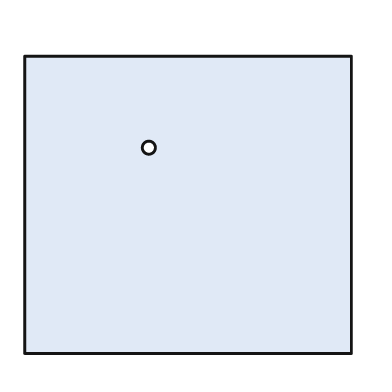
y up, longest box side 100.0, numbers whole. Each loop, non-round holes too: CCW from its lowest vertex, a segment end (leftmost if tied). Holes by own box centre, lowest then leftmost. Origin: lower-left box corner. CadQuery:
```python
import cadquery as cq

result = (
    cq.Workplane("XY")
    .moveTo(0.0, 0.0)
    .lineTo(100.0, 0.0)
    .lineTo(100.0, 91.0)
    .lineTo(0.0, 91.0)
    .close()
    .moveTo(38.0, 63.0)
    .circle(2.0)
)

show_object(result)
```